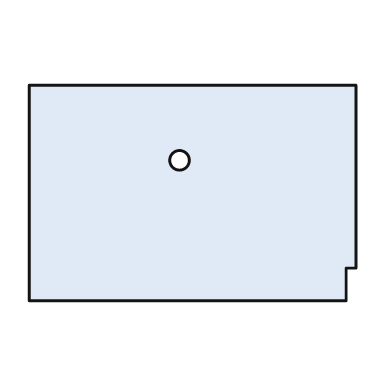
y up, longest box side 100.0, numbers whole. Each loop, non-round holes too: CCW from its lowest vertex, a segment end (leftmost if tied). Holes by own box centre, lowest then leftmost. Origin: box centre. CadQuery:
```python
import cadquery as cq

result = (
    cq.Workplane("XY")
    .moveTo(-50.0, -33.0)
    .lineTo(47.0, -33.0)
    .lineTo(47.0, -23.0)
    .lineTo(50.0, -23.0)
    .lineTo(50.0, 33.0)
    .lineTo(-50.0, 33.0)
    .close()
    .moveTo(-4.0, 10.0)
    .circle(3.0)
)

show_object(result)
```